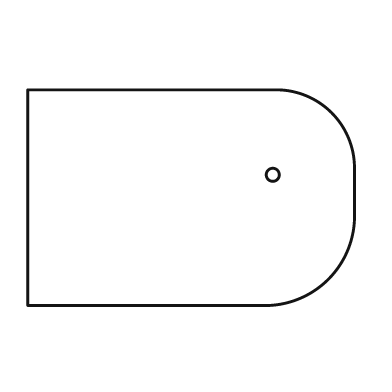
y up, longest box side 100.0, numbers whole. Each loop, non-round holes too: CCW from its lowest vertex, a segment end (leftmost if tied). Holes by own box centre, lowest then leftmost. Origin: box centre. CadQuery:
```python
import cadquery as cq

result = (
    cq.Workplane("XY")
    .moveTo(-50.0, -33.0)
    .lineTo(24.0, -33.0)
    .threePointArc((42.0, -25.0), (50.0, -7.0))
    .lineTo(50.0, 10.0)
    .threePointArc((43.0, 26.0), (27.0, 33.0))
    .lineTo(-50.0, 33.0)
    .close()
    .moveTo(25.0, 7.0)
    .circle(2.0)
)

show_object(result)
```